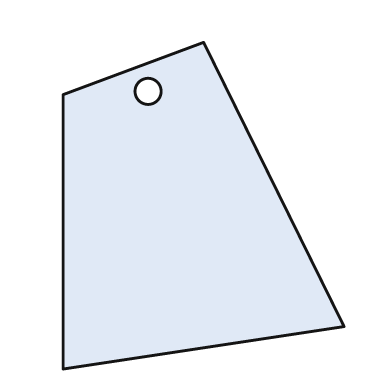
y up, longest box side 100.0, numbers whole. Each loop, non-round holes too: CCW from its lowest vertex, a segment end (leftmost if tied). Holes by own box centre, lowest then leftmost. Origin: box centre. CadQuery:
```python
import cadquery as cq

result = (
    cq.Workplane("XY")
    .moveTo(-43.0, -50.0)
    .lineTo(43.0, -37.0)
    .lineTo(0.0, 50.0)
    .lineTo(-43.0, 34.0)
    .close()
    .moveTo(-17.0, 35.0)
    .circle(4.0)
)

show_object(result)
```